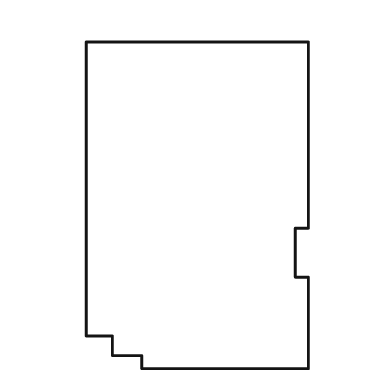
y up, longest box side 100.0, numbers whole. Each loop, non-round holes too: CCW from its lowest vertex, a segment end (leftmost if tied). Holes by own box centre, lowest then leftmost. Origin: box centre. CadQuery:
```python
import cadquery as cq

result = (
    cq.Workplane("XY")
    .moveTo(-17.0, -50.0)
    .lineTo(34.0, -50.0)
    .lineTo(34.0, -22.0)
    .lineTo(30.0, -22.0)
    .lineTo(30.0, -7.0)
    .lineTo(34.0, -7.0)
    .lineTo(34.0, 50.0)
    .lineTo(-34.0, 50.0)
    .lineTo(-34.0, -40.0)
    .lineTo(-26.0, -40.0)
    .lineTo(-26.0, -46.0)
    .lineTo(-17.0, -46.0)
    .close()
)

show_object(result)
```